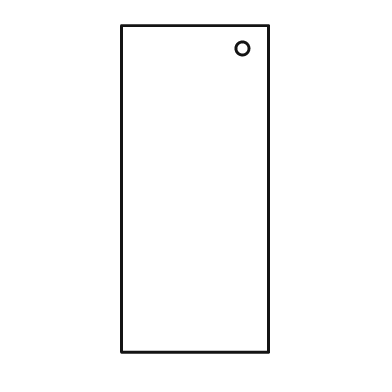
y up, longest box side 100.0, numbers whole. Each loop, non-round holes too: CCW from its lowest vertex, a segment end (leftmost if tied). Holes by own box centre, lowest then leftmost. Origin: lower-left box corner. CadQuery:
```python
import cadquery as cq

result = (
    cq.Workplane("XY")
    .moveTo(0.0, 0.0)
    .lineTo(45.0, 0.0)
    .lineTo(45.0, 100.0)
    .lineTo(0.0, 100.0)
    .close()
    .moveTo(37.0, 93.0)
    .circle(2.0)
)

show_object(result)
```